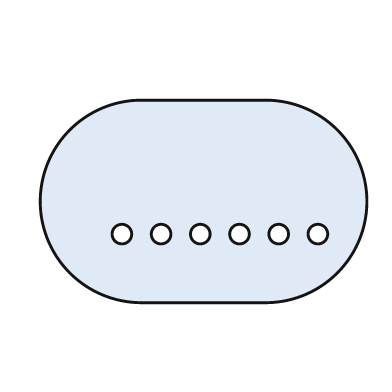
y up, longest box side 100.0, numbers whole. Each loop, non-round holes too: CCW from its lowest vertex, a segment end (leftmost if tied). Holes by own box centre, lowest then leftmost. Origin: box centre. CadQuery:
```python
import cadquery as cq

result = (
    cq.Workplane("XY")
    .moveTo(-19.0, -31.0)
    .lineTo(19.0, -31.0)
    .threePointArc((50.0, 0.0), (19.0, 31.0))
    .lineTo(-19.0, 31.0)
    .threePointArc((-50.0, 0.0), (-19.0, -31.0))
    .close()
    .moveTo(-25.0, -10.0)
    .circle(3.0)
    .moveTo(-13.0, -10.0)
    .circle(3.0)
    .moveTo(-1.0, -10.0)
    .circle(3.0)
    .moveTo(11.0, -10.0)
    .circle(3.0)
    .moveTo(23.0, -10.0)
    .circle(3.0)
    .moveTo(35.0, -10.0)
    .circle(3.0)
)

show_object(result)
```